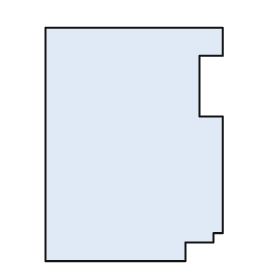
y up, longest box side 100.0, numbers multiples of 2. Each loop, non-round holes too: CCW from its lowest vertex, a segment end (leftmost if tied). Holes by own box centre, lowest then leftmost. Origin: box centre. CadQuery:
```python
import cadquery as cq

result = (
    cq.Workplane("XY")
    .moveTo(-38.0, -50.0)
    .lineTo(22.0, -50.0)
    .lineTo(22.0, -42.0)
    .lineTo(34.0, -42.0)
    .lineTo(34.0, -38.0)
    .lineTo(38.0, -38.0)
    .lineTo(38.0, 12.0)
    .lineTo(28.0, 12.0)
    .lineTo(28.0, 38.0)
    .lineTo(38.0, 38.0)
    .lineTo(38.0, 50.0)
    .lineTo(-38.0, 50.0)
    .close()
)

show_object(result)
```